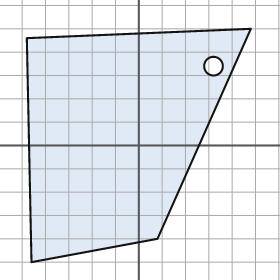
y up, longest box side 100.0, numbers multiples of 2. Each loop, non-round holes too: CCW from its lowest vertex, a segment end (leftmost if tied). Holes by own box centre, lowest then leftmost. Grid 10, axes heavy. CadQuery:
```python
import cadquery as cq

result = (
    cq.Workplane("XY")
    .moveTo(-46.0, -50.0)
    .lineTo(8.0, -40.0)
    .lineTo(48.0, 50.0)
    .lineTo(-48.0, 46.0)
    .close()
    .moveTo(32.0, 34.0)
    .circle(4.0)
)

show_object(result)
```